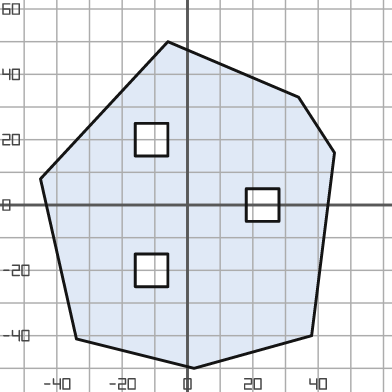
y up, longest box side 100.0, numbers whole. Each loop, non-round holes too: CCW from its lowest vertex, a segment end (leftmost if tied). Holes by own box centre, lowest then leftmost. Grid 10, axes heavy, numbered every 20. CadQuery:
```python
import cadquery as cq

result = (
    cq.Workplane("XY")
    .moveTo(2.0, -50.0)
    .lineTo(38.0, -40.0)
    .lineTo(45.0, 16.0)
    .lineTo(34.0, 33.0)
    .lineTo(-6.0, 50.0)
    .lineTo(-45.0, 8.0)
    .lineTo(-34.0, -41.0)
    .close()
    .moveTo(-16.0, -25.0)
    .lineTo(-6.0, -25.0)
    .lineTo(-6.0, -15.0)
    .lineTo(-16.0, -15.0)
    .close()
    .moveTo(18.0, -5.0)
    .lineTo(28.0, -5.0)
    .lineTo(28.0, 5.0)
    .lineTo(18.0, 5.0)
    .close()
    .moveTo(-16.0, 15.0)
    .lineTo(-6.0, 15.0)
    .lineTo(-6.0, 25.0)
    .lineTo(-16.0, 25.0)
    .close()
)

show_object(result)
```